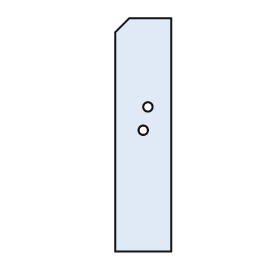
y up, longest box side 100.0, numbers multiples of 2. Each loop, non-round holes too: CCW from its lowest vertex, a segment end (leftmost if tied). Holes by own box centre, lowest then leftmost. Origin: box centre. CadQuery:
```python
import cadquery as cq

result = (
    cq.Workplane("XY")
    .moveTo(-12.0, -50.0)
    .lineTo(12.0, -50.0)
    .lineTo(12.0, 50.0)
    .lineTo(-6.0, 50.0)
    .lineTo(-12.0, 44.0)
    .close()
    .moveTo(0.0, 2.0)
    .circle(2.0)
    .moveTo(2.0, 12.0)
    .circle(2.0)
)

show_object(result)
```